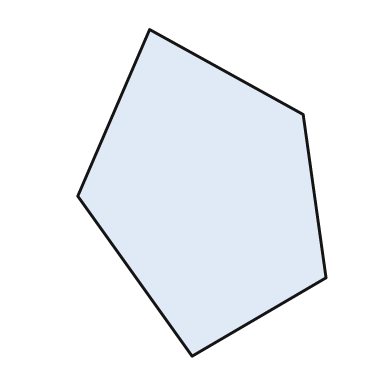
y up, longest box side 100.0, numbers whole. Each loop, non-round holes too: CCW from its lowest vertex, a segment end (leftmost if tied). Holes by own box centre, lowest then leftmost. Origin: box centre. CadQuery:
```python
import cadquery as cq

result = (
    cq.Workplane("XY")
    .moveTo(-3.0, -50.0)
    .lineTo(38.0, -26.0)
    .lineTo(31.0, 24.0)
    .lineTo(-16.0, 50.0)
    .lineTo(-38.0, -1.0)
    .close()
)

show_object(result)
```